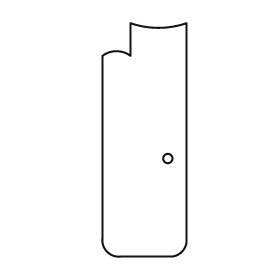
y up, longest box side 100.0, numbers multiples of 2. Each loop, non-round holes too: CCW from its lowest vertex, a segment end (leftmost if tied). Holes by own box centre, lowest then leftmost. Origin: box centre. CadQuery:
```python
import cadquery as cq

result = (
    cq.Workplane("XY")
    .moveTo(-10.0, -50.0)
    .lineTo(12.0, -50.0)
    .threePointArc((16.0, -48.0), (18.0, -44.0))
    .lineTo(18.0, 50.0)
    .threePointArc((6.0, 48.0), (-6.0, 50.0))
    .lineTo(-6.0, 36.0)
    .threePointArc((-12.0, 38.0), (-18.0, 36.0))
    .lineTo(-18.0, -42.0)
    .threePointArc((-16.0, -48.0), (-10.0, -50.0))
    .close()
    .moveTo(10.0, -8.0)
    .circle(2.0)
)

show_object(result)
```